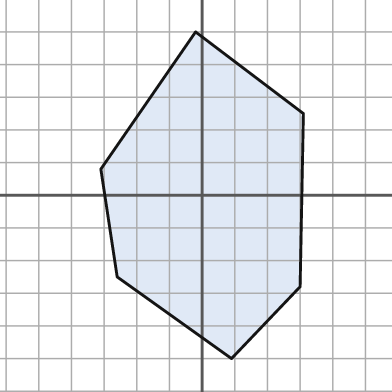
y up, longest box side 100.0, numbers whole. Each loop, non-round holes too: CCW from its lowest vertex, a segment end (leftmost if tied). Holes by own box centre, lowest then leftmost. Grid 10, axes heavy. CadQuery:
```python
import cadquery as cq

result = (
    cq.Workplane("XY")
    .moveTo(9.0, -50.0)
    .lineTo(30.0, -28.0)
    .lineTo(31.0, 25.0)
    .lineTo(-2.0, 50.0)
    .lineTo(-31.0, 8.0)
    .lineTo(-26.0, -25.0)
    .close()
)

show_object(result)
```